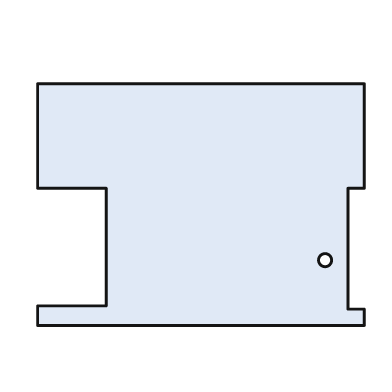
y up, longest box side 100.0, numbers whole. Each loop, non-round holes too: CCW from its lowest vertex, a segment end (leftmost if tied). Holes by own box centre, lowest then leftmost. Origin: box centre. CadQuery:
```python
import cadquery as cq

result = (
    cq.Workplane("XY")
    .moveTo(-50.0, -37.0)
    .lineTo(50.0, -37.0)
    .lineTo(50.0, -32.0)
    .lineTo(45.0, -32.0)
    .lineTo(45.0, 5.0)
    .lineTo(50.0, 5.0)
    .lineTo(50.0, 37.0)
    .lineTo(-50.0, 37.0)
    .lineTo(-50.0, 5.0)
    .lineTo(-29.0, 5.0)
    .lineTo(-29.0, -31.0)
    .lineTo(-50.0, -31.0)
    .close()
    .moveTo(38.0, -17.0)
    .circle(2.0)
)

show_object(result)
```